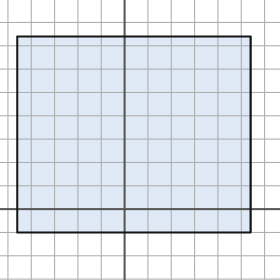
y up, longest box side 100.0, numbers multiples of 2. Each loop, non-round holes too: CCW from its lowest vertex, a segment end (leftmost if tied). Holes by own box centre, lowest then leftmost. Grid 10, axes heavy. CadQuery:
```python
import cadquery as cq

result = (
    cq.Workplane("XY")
    .moveTo(-46.0, -10.0)
    .lineTo(54.0, -10.0)
    .lineTo(54.0, 74.0)
    .lineTo(-46.0, 74.0)
    .close()
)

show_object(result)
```